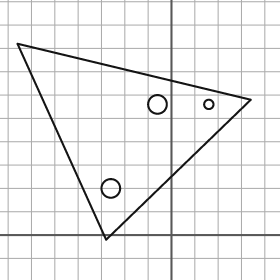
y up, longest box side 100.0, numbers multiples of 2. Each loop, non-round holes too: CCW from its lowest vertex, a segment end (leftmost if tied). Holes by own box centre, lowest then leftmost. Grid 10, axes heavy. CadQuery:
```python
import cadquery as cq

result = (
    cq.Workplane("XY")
    .moveTo(-28.0, -2.0)
    .lineTo(34.0, 58.0)
    .lineTo(-66.0, 82.0)
    .close()
    .moveTo(-26.0, 20.0)
    .circle(4.0)
    .moveTo(-6.0, 56.0)
    .circle(4.0)
    .moveTo(16.0, 56.0)
    .circle(2.0)
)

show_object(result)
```